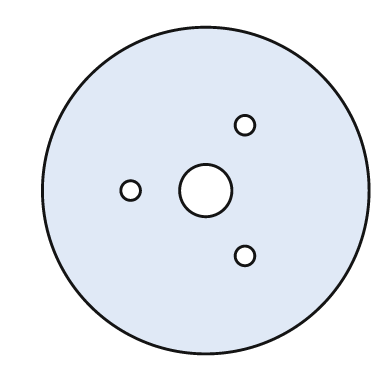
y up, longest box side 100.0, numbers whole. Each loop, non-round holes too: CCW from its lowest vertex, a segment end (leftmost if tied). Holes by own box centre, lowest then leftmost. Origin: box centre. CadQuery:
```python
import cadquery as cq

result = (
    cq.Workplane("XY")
    .moveTo(0.0, 0.0)
    .circle(50.0)
    .moveTo(12.0, -20.0)
    .circle(3.0)
    .moveTo(-23.0, 0.0)
    .circle(3.0)
    .moveTo(0.0, 0.0)
    .circle(8.0)
    .moveTo(12.0, 20.0)
    .circle(3.0)
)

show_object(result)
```